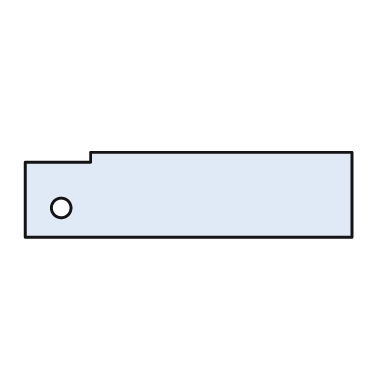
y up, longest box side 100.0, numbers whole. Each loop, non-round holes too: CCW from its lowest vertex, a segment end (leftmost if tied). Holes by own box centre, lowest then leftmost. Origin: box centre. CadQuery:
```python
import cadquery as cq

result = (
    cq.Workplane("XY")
    .moveTo(-50.0, -13.0)
    .lineTo(50.0, -13.0)
    .lineTo(50.0, 13.0)
    .lineTo(-30.0, 13.0)
    .lineTo(-30.0, 10.0)
    .lineTo(-50.0, 10.0)
    .close()
    .moveTo(-39.0, -4.0)
    .circle(3.0)
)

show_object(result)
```